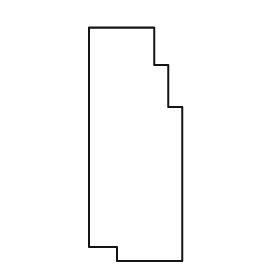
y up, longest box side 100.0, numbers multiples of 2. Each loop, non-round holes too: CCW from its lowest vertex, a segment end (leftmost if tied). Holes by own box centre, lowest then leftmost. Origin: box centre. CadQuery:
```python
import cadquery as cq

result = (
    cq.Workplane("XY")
    .moveTo(-8.0, -50.0)
    .lineTo(20.0, -50.0)
    .lineTo(20.0, 16.0)
    .lineTo(14.0, 16.0)
    .lineTo(14.0, 34.0)
    .lineTo(8.0, 34.0)
    .lineTo(8.0, 50.0)
    .lineTo(-20.0, 50.0)
    .lineTo(-20.0, -44.0)
    .lineTo(-8.0, -44.0)
    .close()
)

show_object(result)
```